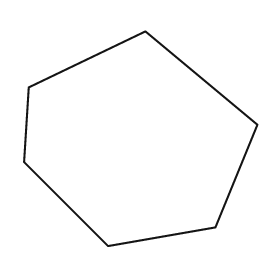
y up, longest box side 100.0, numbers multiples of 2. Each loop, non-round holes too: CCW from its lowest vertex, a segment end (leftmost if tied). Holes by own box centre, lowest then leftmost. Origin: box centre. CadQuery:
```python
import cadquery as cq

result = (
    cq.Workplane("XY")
    .moveTo(-14.0, -46.0)
    .lineTo(32.0, -38.0)
    .lineTo(50.0, 6.0)
    .lineTo(2.0, 46.0)
    .lineTo(-48.0, 22.0)
    .lineTo(-50.0, -10.0)
    .close()
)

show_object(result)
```